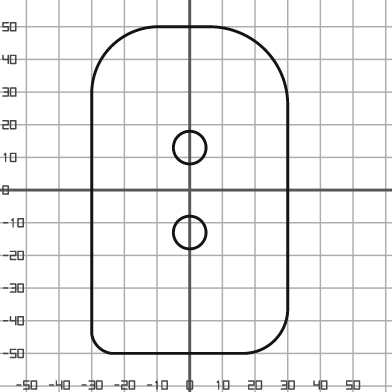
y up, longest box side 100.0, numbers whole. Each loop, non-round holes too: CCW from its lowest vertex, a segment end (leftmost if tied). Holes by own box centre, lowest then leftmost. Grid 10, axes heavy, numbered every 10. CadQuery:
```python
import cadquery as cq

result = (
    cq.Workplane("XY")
    .moveTo(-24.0, -50.0)
    .lineTo(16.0, -50.0)
    .threePointArc((26.0, -46.0), (30.0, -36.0))
    .lineTo(30.0, 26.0)
    .threePointArc((23.0, 43.0), (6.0, 50.0))
    .lineTo(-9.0, 50.0)
    .threePointArc((-24.0, 44.0), (-30.0, 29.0))
    .lineTo(-30.0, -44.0)
    .threePointArc((-28.0, -48.0), (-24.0, -50.0))
    .close()
    .moveTo(0.0, -13.0)
    .circle(5.0)
    .moveTo(0.0, 13.0)
    .circle(5.0)
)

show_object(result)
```